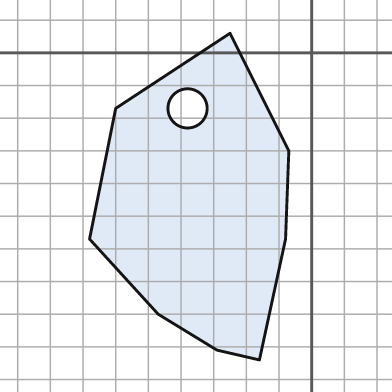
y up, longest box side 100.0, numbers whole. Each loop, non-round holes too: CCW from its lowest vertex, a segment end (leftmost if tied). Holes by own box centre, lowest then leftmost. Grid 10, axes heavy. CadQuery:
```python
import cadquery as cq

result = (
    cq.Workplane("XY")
    .moveTo(-16.0, -94.0)
    .lineTo(-8.0, -57.0)
    .lineTo(-7.0, -30.0)
    .lineTo(-25.0, 6.0)
    .lineTo(-60.0, -17.0)
    .lineTo(-68.0, -57.0)
    .lineTo(-47.0, -80.0)
    .lineTo(-29.0, -91.0)
    .close()
    .moveTo(-38.0, -17.0)
    .circle(6.0)
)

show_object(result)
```